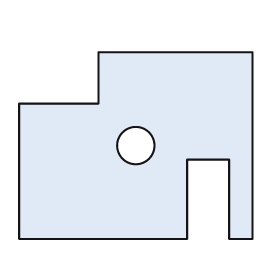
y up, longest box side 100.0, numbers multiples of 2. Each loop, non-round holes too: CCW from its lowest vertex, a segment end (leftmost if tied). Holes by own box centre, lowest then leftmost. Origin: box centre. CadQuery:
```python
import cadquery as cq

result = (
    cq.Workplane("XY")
    .moveTo(-50.0, -40.0)
    .lineTo(22.0, -40.0)
    .lineTo(22.0, -6.0)
    .lineTo(40.0, -6.0)
    .lineTo(40.0, -40.0)
    .lineTo(50.0, -40.0)
    .lineTo(50.0, 40.0)
    .lineTo(-16.0, 40.0)
    .lineTo(-16.0, 18.0)
    .lineTo(-50.0, 18.0)
    .close()
    .moveTo(0.0, 0.0)
    .circle(8.0)
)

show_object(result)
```